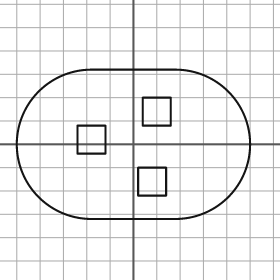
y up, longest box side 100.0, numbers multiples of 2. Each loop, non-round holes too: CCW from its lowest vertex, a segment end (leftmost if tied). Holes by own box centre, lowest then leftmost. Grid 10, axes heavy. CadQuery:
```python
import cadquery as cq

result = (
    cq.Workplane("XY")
    .moveTo(-18.0, -32.0)
    .lineTo(18.0, -32.0)
    .threePointArc((50.0, 0.0), (18.0, 32.0))
    .lineTo(-18.0, 32.0)
    .threePointArc((-50.0, 0.0), (-18.0, -32.0))
    .close()
    .moveTo(2.0, -22.0)
    .lineTo(14.0, -22.0)
    .lineTo(14.0, -10.0)
    .lineTo(2.0, -10.0)
    .close()
    .moveTo(-24.0, -4.0)
    .lineTo(-12.0, -4.0)
    .lineTo(-12.0, 8.0)
    .lineTo(-24.0, 8.0)
    .close()
    .moveTo(4.0, 8.0)
    .lineTo(16.0, 8.0)
    .lineTo(16.0, 20.0)
    .lineTo(4.0, 20.0)
    .close()
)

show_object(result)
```